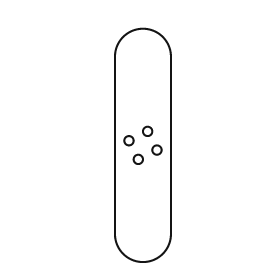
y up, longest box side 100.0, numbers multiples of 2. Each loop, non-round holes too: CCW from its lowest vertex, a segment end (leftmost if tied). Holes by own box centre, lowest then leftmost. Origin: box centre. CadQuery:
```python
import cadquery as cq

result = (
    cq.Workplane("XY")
    .moveTo(-12.0, -38.0)
    .threePointArc((0.0, -50.0), (12.0, -38.0))
    .lineTo(12.0, 38.0)
    .threePointArc((0.0, 50.0), (-12.0, 38.0))
    .close()
    .moveTo(-2.0, -6.0)
    .circle(2.0)
    .moveTo(6.0, -2.0)
    .circle(2.0)
    .moveTo(-6.0, 2.0)
    .circle(2.0)
    .moveTo(2.0, 6.0)
    .circle(2.0)
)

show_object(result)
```